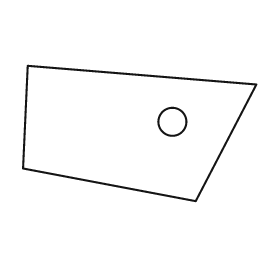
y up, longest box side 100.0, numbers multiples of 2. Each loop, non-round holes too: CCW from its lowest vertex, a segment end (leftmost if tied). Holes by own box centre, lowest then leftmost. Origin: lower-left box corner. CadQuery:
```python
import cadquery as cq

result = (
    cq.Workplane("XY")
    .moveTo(74.0, 0.0)
    .lineTo(100.0, 50.0)
    .lineTo(2.0, 58.0)
    .lineTo(0.0, 14.0)
    .close()
    .moveTo(64.0, 34.0)
    .circle(6.0)
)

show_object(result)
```